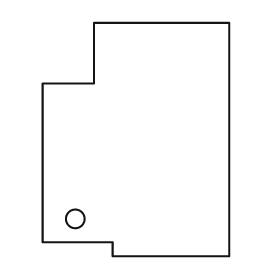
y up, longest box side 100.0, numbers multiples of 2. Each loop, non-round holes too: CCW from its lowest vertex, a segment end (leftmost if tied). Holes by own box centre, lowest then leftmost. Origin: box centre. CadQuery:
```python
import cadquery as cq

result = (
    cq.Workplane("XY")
    .moveTo(-10.0, -50.0)
    .lineTo(40.0, -50.0)
    .lineTo(40.0, 50.0)
    .lineTo(-18.0, 50.0)
    .lineTo(-18.0, 24.0)
    .lineTo(-40.0, 24.0)
    .lineTo(-40.0, -44.0)
    .lineTo(-10.0, -44.0)
    .close()
    .moveTo(-26.0, -34.0)
    .circle(4.0)
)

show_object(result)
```